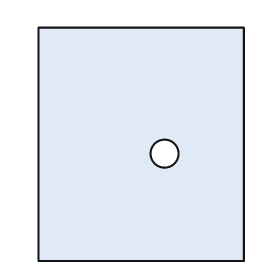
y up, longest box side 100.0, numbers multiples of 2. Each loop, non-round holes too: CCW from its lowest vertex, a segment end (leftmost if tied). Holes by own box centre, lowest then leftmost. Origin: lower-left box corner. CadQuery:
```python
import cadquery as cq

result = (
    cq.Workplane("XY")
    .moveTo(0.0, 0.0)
    .lineTo(88.0, 0.0)
    .lineTo(88.0, 100.0)
    .lineTo(0.0, 100.0)
    .close()
    .moveTo(54.0, 46.0)
    .circle(6.0)
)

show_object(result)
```